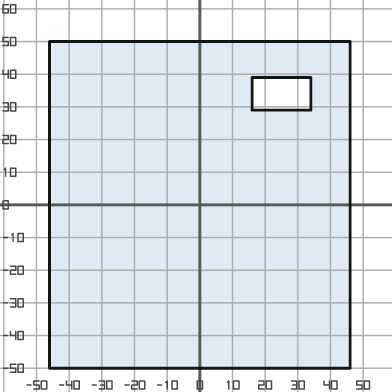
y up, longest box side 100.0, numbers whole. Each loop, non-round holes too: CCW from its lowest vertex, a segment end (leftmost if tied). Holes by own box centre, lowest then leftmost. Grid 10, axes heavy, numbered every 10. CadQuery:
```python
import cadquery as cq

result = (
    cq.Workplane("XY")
    .moveTo(-46.0, -50.0)
    .lineTo(46.0, -50.0)
    .lineTo(46.0, 50.0)
    .lineTo(-46.0, 50.0)
    .close()
    .moveTo(16.0, 29.0)
    .lineTo(34.0, 29.0)
    .lineTo(34.0, 39.0)
    .lineTo(16.0, 39.0)
    .close()
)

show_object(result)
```